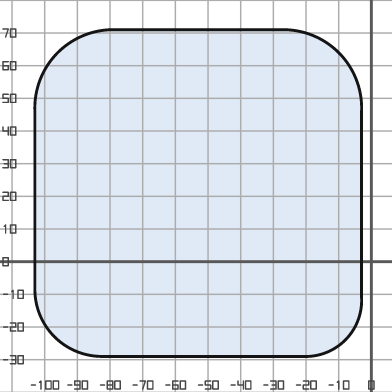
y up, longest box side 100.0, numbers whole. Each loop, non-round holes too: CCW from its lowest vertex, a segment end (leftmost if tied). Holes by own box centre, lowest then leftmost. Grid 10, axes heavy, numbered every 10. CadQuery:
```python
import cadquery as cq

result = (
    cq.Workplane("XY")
    .moveTo(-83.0, -29.0)
    .lineTo(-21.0, -29.0)
    .threePointArc((-8.0, -24.0), (-3.0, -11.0))
    .lineTo(-3.0, 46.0)
    .threePointArc((-10.0, 64.0), (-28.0, 71.0))
    .lineTo(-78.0, 71.0)
    .threePointArc((-96.0, 64.0), (-103.0, 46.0))
    .lineTo(-103.0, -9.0)
    .threePointArc((-97.0, -23.0), (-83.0, -29.0))
    .close()
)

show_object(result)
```